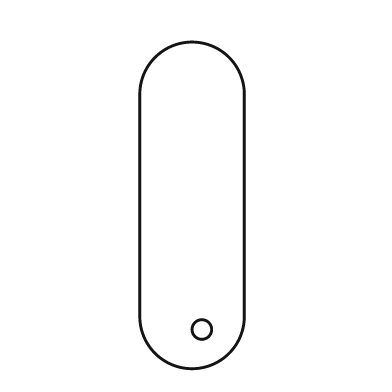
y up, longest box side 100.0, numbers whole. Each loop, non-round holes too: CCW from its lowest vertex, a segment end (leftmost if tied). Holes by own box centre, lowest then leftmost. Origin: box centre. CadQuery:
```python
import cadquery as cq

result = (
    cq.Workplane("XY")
    .moveTo(-16.0, -34.0)
    .threePointArc((0.0, -50.0), (16.0, -34.0))
    .lineTo(16.0, 34.0)
    .threePointArc((0.0, 50.0), (-16.0, 34.0))
    .close()
    .moveTo(3.0, -38.0)
    .circle(3.0)
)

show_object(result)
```